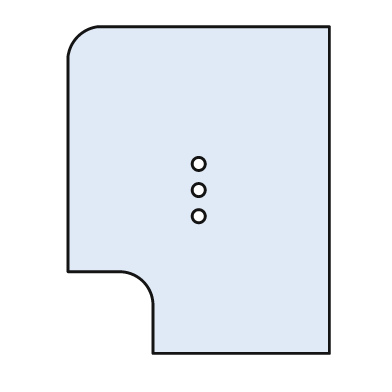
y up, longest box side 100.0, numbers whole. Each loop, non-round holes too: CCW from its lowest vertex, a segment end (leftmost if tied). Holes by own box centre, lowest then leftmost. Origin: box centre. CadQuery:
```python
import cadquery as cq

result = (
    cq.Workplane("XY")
    .moveTo(-14.0, -50.0)
    .lineTo(40.0, -50.0)
    .lineTo(40.0, 50.0)
    .lineTo(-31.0, 50.0)
    .threePointArc((-37.0, 47.0), (-40.0, 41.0))
    .lineTo(-40.0, -25.0)
    .lineTo(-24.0, -25.0)
    .threePointArc((-17.0, -28.0), (-14.0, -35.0))
    .close()
    .moveTo(0.0, -8.0)
    .circle(2.0)
    .moveTo(0.0, 0.0)
    .circle(2.0)
    .moveTo(0.0, 8.0)
    .circle(2.0)
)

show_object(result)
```